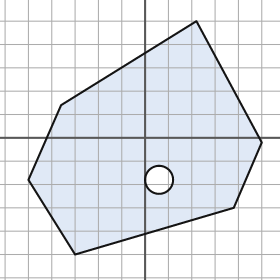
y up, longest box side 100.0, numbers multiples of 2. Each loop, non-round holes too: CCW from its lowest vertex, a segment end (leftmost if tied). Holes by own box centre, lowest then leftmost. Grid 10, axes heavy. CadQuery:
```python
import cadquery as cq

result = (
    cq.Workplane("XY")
    .moveTo(-30.0, -50.0)
    .lineTo(38.0, -30.0)
    .lineTo(50.0, -2.0)
    .lineTo(22.0, 50.0)
    .lineTo(-36.0, 14.0)
    .lineTo(-50.0, -18.0)
    .close()
    .moveTo(6.0, -18.0)
    .circle(6.0)
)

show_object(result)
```